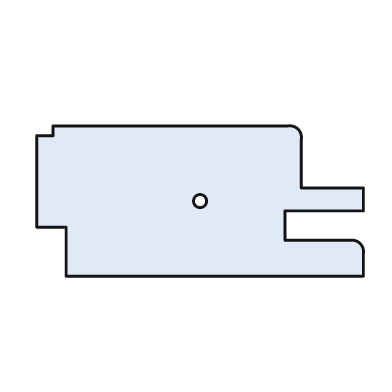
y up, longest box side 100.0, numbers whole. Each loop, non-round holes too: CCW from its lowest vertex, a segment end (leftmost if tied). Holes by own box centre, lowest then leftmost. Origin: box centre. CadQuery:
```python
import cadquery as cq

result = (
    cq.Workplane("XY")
    .moveTo(-41.0, -23.0)
    .lineTo(50.0, -23.0)
    .lineTo(50.0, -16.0)
    .threePointArc((49.0, -13.0), (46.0, -12.0))
    .lineTo(26.0, -12.0)
    .lineTo(26.0, -3.0)
    .lineTo(50.0, -3.0)
    .lineTo(50.0, 4.0)
    .lineTo(31.0, 4.0)
    .lineTo(31.0, 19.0)
    .threePointArc((30.0, 22.0), (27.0, 23.0))
    .lineTo(-45.0, 23.0)
    .lineTo(-45.0, 20.0)
    .lineTo(-50.0, 20.0)
    .lineTo(-50.0, -8.0)
    .lineTo(-41.0, -8.0)
    .close()
    .moveTo(0.0, 0.0)
    .circle(2.0)
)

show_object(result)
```